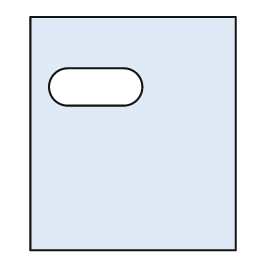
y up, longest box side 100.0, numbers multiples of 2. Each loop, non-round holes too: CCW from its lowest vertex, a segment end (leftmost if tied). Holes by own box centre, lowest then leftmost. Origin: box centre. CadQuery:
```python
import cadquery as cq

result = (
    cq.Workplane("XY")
    .moveTo(-44.0, -50.0)
    .lineTo(44.0, -50.0)
    .lineTo(44.0, 50.0)
    .lineTo(-44.0, 50.0)
    .close()
    .moveTo(-28.0, 12.0)
    .lineTo(-4.0, 12.0)
    .threePointArc((4.0, 20.0), (-4.0, 28.0))
    .lineTo(-28.0, 28.0)
    .threePointArc((-36.0, 20.0), (-28.0, 12.0))
    .close()
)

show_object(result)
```